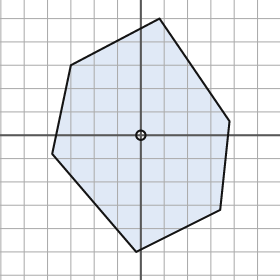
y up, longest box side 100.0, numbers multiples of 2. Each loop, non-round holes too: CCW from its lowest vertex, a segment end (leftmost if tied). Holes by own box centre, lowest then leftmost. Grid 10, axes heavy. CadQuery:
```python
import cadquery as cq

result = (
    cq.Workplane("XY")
    .moveTo(-2.0, -50.0)
    .lineTo(34.0, -32.0)
    .lineTo(38.0, 6.0)
    .lineTo(8.0, 50.0)
    .lineTo(-30.0, 30.0)
    .lineTo(-38.0, -8.0)
    .close()
    .moveTo(0.0, 0.0)
    .circle(2.0)
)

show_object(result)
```